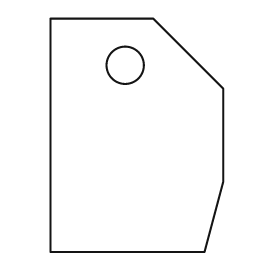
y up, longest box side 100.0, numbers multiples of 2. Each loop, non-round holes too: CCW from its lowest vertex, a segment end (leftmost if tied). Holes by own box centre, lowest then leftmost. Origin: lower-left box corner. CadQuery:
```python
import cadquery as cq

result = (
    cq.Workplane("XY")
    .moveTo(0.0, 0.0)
    .lineTo(66.0, 0.0)
    .lineTo(74.0, 30.0)
    .lineTo(74.0, 70.0)
    .lineTo(44.0, 100.0)
    .lineTo(0.0, 100.0)
    .close()
    .moveTo(32.0, 80.0)
    .circle(8.0)
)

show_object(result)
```